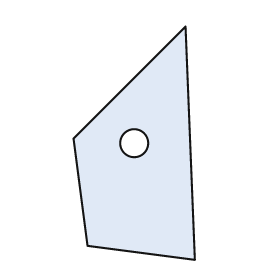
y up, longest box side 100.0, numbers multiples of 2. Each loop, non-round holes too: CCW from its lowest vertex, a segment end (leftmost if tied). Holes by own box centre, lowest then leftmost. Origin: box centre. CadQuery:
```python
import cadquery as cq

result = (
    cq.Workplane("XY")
    .moveTo(26.0, -50.0)
    .lineTo(22.0, 50.0)
    .lineTo(-26.0, 2.0)
    .lineTo(-20.0, -44.0)
    .close()
    .moveTo(0.0, 0.0)
    .circle(6.0)
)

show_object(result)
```